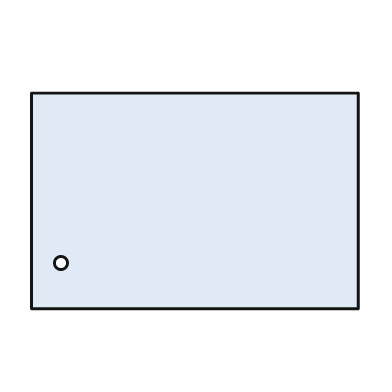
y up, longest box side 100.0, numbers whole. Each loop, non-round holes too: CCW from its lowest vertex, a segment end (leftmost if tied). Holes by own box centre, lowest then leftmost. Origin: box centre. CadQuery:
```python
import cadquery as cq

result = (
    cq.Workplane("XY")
    .moveTo(-50.0, -33.0)
    .lineTo(50.0, -33.0)
    .lineTo(50.0, 33.0)
    .lineTo(-50.0, 33.0)
    .close()
    .moveTo(-41.0, -19.0)
    .circle(2.0)
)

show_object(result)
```